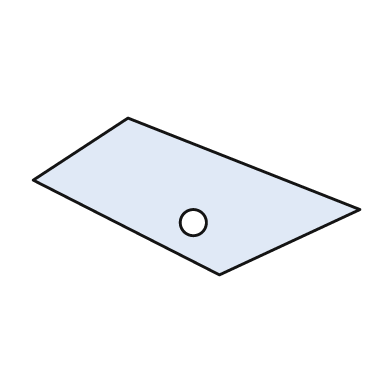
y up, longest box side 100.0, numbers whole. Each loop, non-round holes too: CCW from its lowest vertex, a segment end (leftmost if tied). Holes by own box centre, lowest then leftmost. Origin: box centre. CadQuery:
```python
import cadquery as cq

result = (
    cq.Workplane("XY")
    .moveTo(7.0, -24.0)
    .lineTo(50.0, -4.0)
    .lineTo(-21.0, 24.0)
    .lineTo(-50.0, 5.0)
    .close()
    .moveTo(-1.0, -8.0)
    .circle(4.0)
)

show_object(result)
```